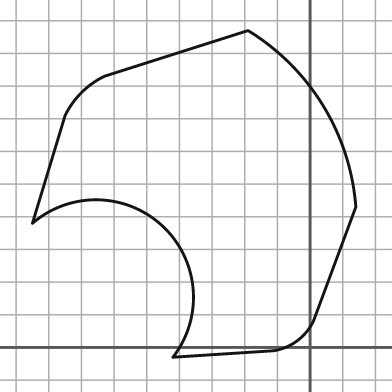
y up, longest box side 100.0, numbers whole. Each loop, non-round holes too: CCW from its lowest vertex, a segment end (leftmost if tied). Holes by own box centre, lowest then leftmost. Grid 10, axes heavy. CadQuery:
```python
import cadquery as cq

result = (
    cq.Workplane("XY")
    .moveTo(-42.0, -3.0)
    .lineTo(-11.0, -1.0)
    .threePointArc((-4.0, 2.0), (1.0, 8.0))
    .lineTo(14.0, 43.0)
    .threePointArc((4.0, 74.0), (-19.0, 97.0))
    .lineTo(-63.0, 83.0)
    .threePointArc((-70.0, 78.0), (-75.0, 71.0))
    .lineTo(-85.0, 38.0)
    .threePointArc((-45.0, 37.0), (-42.0, -3.0))
    .close()
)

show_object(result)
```